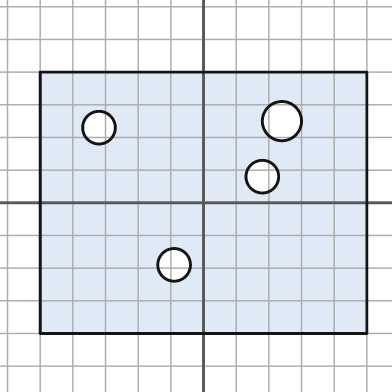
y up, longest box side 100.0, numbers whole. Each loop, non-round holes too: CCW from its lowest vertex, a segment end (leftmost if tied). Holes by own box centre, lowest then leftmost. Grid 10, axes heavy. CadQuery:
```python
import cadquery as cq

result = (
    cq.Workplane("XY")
    .moveTo(-50.0, -40.0)
    .lineTo(50.0, -40.0)
    .lineTo(50.0, 40.0)
    .lineTo(-50.0, 40.0)
    .close()
    .moveTo(-9.0, -19.0)
    .circle(5.0)
    .moveTo(18.0, 8.0)
    .circle(5.0)
    .moveTo(-32.0, 23.0)
    .circle(5.0)
    .moveTo(24.0, 25.0)
    .circle(6.0)
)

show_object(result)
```